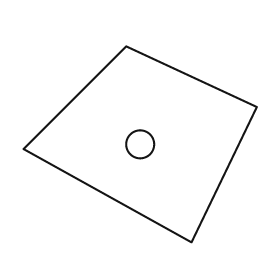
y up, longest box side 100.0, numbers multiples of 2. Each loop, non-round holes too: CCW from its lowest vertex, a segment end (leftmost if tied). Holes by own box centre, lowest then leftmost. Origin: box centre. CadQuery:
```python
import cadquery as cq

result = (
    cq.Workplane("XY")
    .moveTo(22.0, -42.0)
    .lineTo(50.0, 16.0)
    .lineTo(-6.0, 42.0)
    .lineTo(-50.0, -2.0)
    .close()
    .moveTo(0.0, 0.0)
    .circle(6.0)
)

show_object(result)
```